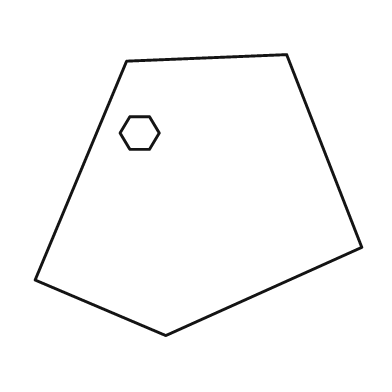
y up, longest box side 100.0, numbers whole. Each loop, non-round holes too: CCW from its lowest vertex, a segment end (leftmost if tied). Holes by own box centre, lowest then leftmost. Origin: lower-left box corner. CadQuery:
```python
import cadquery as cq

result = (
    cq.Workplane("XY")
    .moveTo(40.0, 0.0)
    .lineTo(100.0, 27.0)
    .lineTo(77.0, 86.0)
    .lineTo(28.0, 84.0)
    .lineTo(0.0, 17.0)
    .close()
    .moveTo(29.0, 57.0)
    .lineTo(35.0, 57.0)
    .lineTo(38.0, 62.0)
    .lineTo(35.0, 67.0)
    .lineTo(29.0, 67.0)
    .lineTo(26.0, 62.0)
    .close()
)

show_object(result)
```